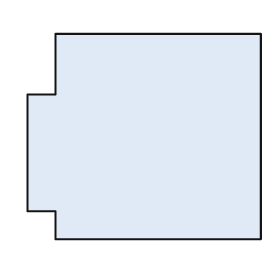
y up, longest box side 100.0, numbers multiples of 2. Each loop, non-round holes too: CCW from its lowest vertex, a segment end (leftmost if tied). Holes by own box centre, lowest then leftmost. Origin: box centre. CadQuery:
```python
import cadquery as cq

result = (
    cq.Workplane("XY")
    .moveTo(-38.0, -44.0)
    .lineTo(50.0, -44.0)
    .lineTo(50.0, 44.0)
    .lineTo(-38.0, 44.0)
    .lineTo(-38.0, 18.0)
    .lineTo(-50.0, 18.0)
    .lineTo(-50.0, -32.0)
    .lineTo(-38.0, -32.0)
    .close()
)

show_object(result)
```